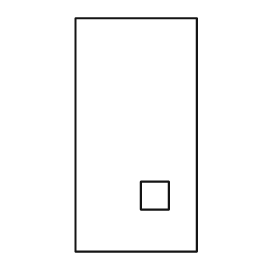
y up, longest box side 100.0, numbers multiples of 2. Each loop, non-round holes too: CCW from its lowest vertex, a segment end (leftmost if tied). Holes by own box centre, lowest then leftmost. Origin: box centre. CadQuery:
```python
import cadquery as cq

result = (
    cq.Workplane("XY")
    .moveTo(-26.0, -50.0)
    .lineTo(26.0, -50.0)
    .lineTo(26.0, 50.0)
    .lineTo(-26.0, 50.0)
    .close()
    .moveTo(2.0, -32.0)
    .lineTo(14.0, -32.0)
    .lineTo(14.0, -20.0)
    .lineTo(2.0, -20.0)
    .close()
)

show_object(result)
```